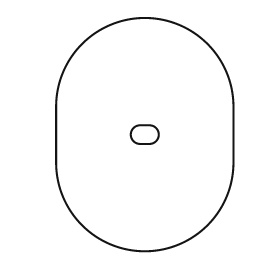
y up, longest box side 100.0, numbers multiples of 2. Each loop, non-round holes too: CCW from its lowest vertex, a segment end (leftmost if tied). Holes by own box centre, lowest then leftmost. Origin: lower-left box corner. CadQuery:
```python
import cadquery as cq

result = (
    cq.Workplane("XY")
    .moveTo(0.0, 38.0)
    .threePointArc((38.0, 0.0), (76.0, 38.0))
    .lineTo(76.0, 62.0)
    .threePointArc((38.0, 100.0), (0.0, 62.0))
    .close()
    .moveTo(36.0, 46.0)
    .lineTo(40.0, 46.0)
    .threePointArc((44.0, 50.0), (40.0, 54.0))
    .lineTo(36.0, 54.0)
    .threePointArc((32.0, 50.0), (36.0, 46.0))
    .close()
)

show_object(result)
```